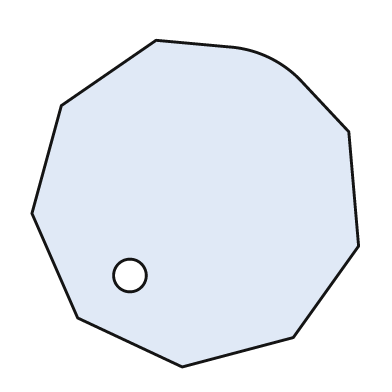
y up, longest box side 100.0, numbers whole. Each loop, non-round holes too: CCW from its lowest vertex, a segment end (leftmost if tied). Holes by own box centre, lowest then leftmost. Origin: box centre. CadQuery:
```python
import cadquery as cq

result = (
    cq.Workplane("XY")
    .moveTo(-4.0, -50.0)
    .lineTo(30.0, -41.0)
    .lineTo(50.0, -13.0)
    .lineTo(47.0, 22.0)
    .lineTo(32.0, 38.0)
    .threePointArc((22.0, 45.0), (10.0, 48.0))
    .lineTo(-12.0, 50.0)
    .lineTo(-41.0, 30.0)
    .lineTo(-50.0, -3.0)
    .lineTo(-36.0, -35.0)
    .close()
    .moveTo(-20.0, -22.0)
    .circle(5.0)
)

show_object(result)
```